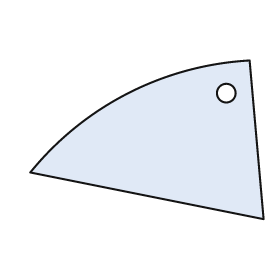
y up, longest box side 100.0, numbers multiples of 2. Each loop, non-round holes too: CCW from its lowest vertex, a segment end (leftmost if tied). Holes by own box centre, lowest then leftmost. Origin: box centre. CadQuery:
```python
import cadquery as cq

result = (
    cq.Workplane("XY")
    .moveTo(50.0, -34.0)
    .lineTo(44.0, 34.0)
    .threePointArc((-8.0, 20.0), (-50.0, -14.0))
    .close()
    .moveTo(34.0, 20.0)
    .circle(4.0)
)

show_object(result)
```